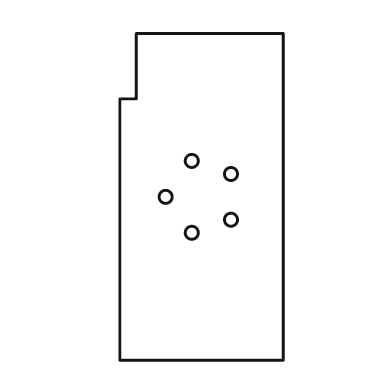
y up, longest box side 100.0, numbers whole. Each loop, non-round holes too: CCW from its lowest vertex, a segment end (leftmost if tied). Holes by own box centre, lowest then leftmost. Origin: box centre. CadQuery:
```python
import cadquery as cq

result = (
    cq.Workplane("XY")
    .moveTo(-25.0, -50.0)
    .lineTo(25.0, -50.0)
    .lineTo(25.0, 50.0)
    .lineTo(-20.0, 50.0)
    .lineTo(-20.0, 30.0)
    .lineTo(-25.0, 30.0)
    .close()
    .moveTo(-3.0, -11.0)
    .circle(2.0)
    .moveTo(9.0, -7.0)
    .circle(2.0)
    .moveTo(-11.0, 0.0)
    .circle(2.0)
    .moveTo(9.0, 7.0)
    .circle(2.0)
    .moveTo(-3.0, 11.0)
    .circle(2.0)
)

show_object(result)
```